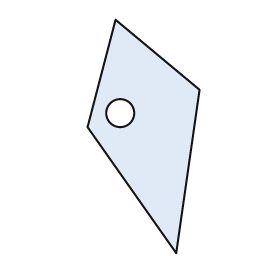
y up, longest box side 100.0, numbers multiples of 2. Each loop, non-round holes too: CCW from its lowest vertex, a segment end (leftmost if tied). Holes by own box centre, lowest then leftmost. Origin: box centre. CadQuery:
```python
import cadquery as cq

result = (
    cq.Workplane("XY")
    .moveTo(14.0, -50.0)
    .lineTo(24.0, 20.0)
    .lineTo(-12.0, 50.0)
    .lineTo(-24.0, 4.0)
    .close()
    .moveTo(-10.0, 10.0)
    .circle(6.0)
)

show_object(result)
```